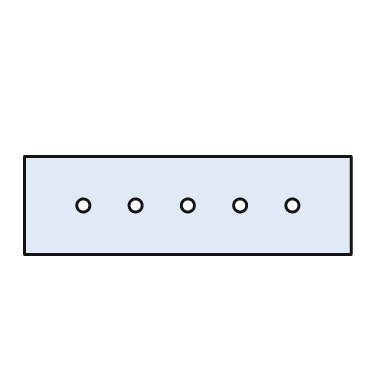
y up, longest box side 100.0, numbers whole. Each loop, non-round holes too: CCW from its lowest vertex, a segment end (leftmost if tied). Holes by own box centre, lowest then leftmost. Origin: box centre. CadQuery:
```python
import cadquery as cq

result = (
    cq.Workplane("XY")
    .moveTo(-50.0, -15.0)
    .lineTo(50.0, -15.0)
    .lineTo(50.0, 15.0)
    .lineTo(-50.0, 15.0)
    .close()
    .moveTo(-32.0, 0.0)
    .circle(2.0)
    .moveTo(-16.0, 0.0)
    .circle(2.0)
    .moveTo(0.0, 0.0)
    .circle(2.0)
    .moveTo(16.0, 0.0)
    .circle(2.0)
    .moveTo(32.0, 0.0)
    .circle(2.0)
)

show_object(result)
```